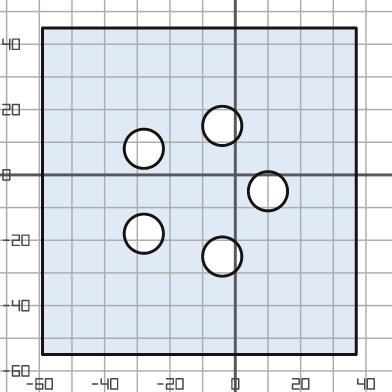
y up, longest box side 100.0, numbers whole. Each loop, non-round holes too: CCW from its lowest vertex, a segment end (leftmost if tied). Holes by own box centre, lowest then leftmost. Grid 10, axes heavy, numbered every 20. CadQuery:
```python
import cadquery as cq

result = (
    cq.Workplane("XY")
    .moveTo(-59.0, -55.0)
    .lineTo(37.0, -55.0)
    .lineTo(37.0, 45.0)
    .lineTo(-59.0, 45.0)
    .close()
    .moveTo(-4.0, -25.0)
    .circle(6.0)
    .moveTo(-28.0, -18.0)
    .circle(6.0)
    .moveTo(10.0, -5.0)
    .circle(6.0)
    .moveTo(-28.0, 8.0)
    .circle(6.0)
    .moveTo(-4.0, 15.0)
    .circle(6.0)
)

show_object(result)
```